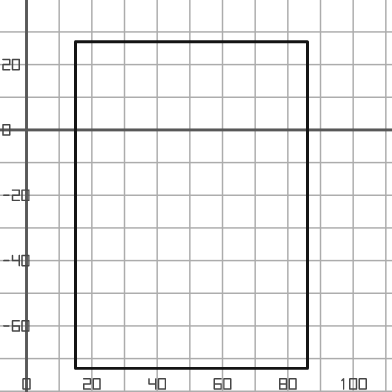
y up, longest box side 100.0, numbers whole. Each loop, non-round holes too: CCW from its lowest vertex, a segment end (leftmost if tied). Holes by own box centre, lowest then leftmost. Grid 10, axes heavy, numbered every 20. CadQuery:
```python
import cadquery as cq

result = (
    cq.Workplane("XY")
    .moveTo(15.0, -73.0)
    .lineTo(86.0, -73.0)
    .lineTo(86.0, 27.0)
    .lineTo(15.0, 27.0)
    .close()
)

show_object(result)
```